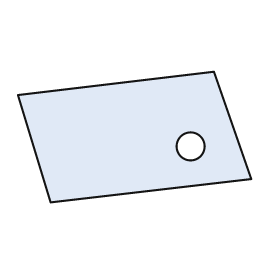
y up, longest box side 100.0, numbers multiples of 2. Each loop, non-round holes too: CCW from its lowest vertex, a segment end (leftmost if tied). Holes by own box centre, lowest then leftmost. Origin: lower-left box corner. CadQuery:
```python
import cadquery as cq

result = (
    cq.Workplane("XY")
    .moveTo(14.0, 0.0)
    .lineTo(100.0, 10.0)
    .lineTo(84.0, 56.0)
    .lineTo(0.0, 46.0)
    .close()
    .moveTo(74.0, 24.0)
    .circle(6.0)
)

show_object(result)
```